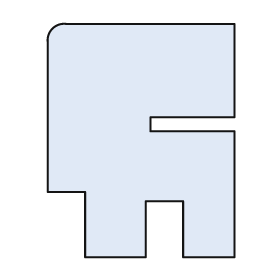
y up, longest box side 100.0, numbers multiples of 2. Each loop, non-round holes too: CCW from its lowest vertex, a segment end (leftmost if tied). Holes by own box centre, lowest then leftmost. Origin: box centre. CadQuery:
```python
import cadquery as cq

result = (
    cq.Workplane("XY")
    .moveTo(-24.0, -50.0)
    .lineTo(2.0, -50.0)
    .lineTo(2.0, -26.0)
    .lineTo(18.0, -26.0)
    .lineTo(18.0, -50.0)
    .lineTo(40.0, -50.0)
    .lineTo(40.0, 4.0)
    .lineTo(4.0, 4.0)
    .lineTo(4.0, 10.0)
    .lineTo(40.0, 10.0)
    .lineTo(40.0, 50.0)
    .lineTo(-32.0, 50.0)
    .threePointArc((-38.0, 48.0), (-40.0, 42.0))
    .lineTo(-40.0, -22.0)
    .lineTo(-24.0, -22.0)
    .close()
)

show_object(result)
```